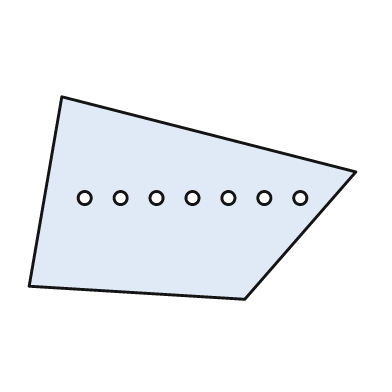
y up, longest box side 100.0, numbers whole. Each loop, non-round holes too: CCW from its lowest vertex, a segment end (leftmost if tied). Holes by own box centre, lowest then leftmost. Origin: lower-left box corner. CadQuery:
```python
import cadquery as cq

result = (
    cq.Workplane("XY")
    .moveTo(66.0, 0.0)
    .lineTo(100.0, 39.0)
    .lineTo(10.0, 62.0)
    .lineTo(0.0, 4.0)
    .close()
    .moveTo(17.0, 31.0)
    .circle(2.0)
    .moveTo(28.0, 31.0)
    .circle(2.0)
    .moveTo(39.0, 31.0)
    .circle(2.0)
    .moveTo(50.0, 31.0)
    .circle(2.0)
    .moveTo(61.0, 31.0)
    .circle(2.0)
    .moveTo(72.0, 31.0)
    .circle(2.0)
    .moveTo(83.0, 31.0)
    .circle(2.0)
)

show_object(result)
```